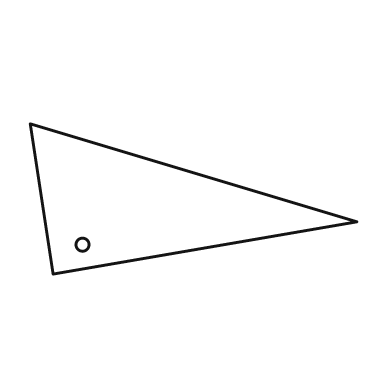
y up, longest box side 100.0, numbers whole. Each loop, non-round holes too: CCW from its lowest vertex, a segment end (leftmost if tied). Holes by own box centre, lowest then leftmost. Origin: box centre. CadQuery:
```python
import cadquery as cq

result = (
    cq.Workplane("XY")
    .moveTo(-43.0, -23.0)
    .lineTo(50.0, -7.0)
    .lineTo(-50.0, 23.0)
    .close()
    .moveTo(-34.0, -14.0)
    .circle(2.0)
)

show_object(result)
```